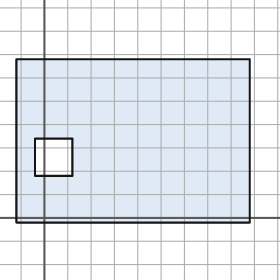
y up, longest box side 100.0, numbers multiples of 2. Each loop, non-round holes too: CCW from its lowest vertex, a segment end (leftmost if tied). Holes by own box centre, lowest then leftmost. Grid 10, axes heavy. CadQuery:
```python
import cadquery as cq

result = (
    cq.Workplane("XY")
    .moveTo(-12.0, -2.0)
    .lineTo(88.0, -2.0)
    .lineTo(88.0, 68.0)
    .lineTo(-12.0, 68.0)
    .close()
    .moveTo(-4.0, 18.0)
    .lineTo(12.0, 18.0)
    .lineTo(12.0, 34.0)
    .lineTo(-4.0, 34.0)
    .close()
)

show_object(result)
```